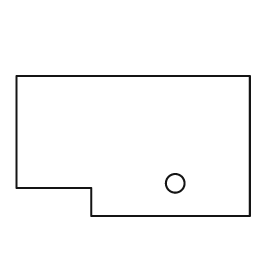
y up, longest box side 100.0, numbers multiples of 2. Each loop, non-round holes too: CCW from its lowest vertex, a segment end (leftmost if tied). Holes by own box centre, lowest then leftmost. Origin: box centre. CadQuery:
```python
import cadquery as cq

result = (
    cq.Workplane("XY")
    .moveTo(-18.0, -30.0)
    .lineTo(50.0, -30.0)
    .lineTo(50.0, 30.0)
    .lineTo(-50.0, 30.0)
    .lineTo(-50.0, -18.0)
    .lineTo(-18.0, -18.0)
    .close()
    .moveTo(18.0, -16.0)
    .circle(4.0)
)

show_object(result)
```